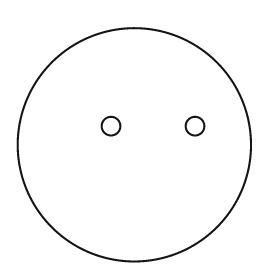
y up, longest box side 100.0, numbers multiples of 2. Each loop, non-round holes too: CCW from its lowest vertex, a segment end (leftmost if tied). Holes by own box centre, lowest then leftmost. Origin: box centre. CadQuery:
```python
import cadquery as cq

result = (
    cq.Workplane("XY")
    .moveTo(0.0, 0.0)
    .circle(50.0)
    .moveTo(-10.0, 8.0)
    .circle(4.0)
    .moveTo(26.0, 8.0)
    .circle(4.0)
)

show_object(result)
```